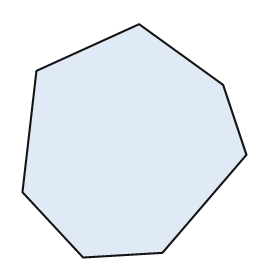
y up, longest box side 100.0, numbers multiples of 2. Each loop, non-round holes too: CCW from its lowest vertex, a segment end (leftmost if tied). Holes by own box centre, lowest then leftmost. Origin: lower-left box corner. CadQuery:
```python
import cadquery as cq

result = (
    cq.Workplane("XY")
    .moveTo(26.0, 0.0)
    .lineTo(60.0, 2.0)
    .lineTo(96.0, 44.0)
    .lineTo(86.0, 74.0)
    .lineTo(50.0, 100.0)
    .lineTo(6.0, 80.0)
    .lineTo(0.0, 28.0)
    .close()
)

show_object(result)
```